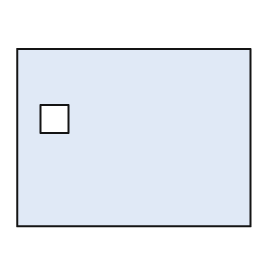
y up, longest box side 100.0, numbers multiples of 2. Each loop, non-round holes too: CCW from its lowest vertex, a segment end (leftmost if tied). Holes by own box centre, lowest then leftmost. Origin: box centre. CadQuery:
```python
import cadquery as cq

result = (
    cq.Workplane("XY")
    .moveTo(-50.0, -38.0)
    .lineTo(50.0, -38.0)
    .lineTo(50.0, 38.0)
    .lineTo(-50.0, 38.0)
    .close()
    .moveTo(-40.0, 2.0)
    .lineTo(-28.0, 2.0)
    .lineTo(-28.0, 14.0)
    .lineTo(-40.0, 14.0)
    .close()
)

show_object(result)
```